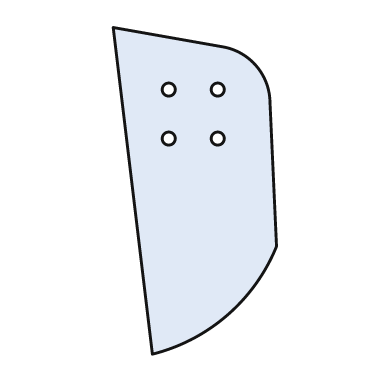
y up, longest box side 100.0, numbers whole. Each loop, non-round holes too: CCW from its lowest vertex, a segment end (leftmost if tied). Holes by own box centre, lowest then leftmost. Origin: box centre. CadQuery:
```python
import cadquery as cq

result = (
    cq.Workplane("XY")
    .moveTo(-13.0, -50.0)
    .threePointArc((10.0, -38.0), (25.0, -17.0))
    .lineTo(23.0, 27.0)
    .threePointArc((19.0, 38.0), (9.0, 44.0))
    .lineTo(-25.0, 50.0)
    .close()
    .moveTo(-8.0, 16.0)
    .circle(2.0)
    .moveTo(7.0, 16.0)
    .circle(2.0)
    .moveTo(-8.0, 31.0)
    .circle(2.0)
    .moveTo(7.0, 31.0)
    .circle(2.0)
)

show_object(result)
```